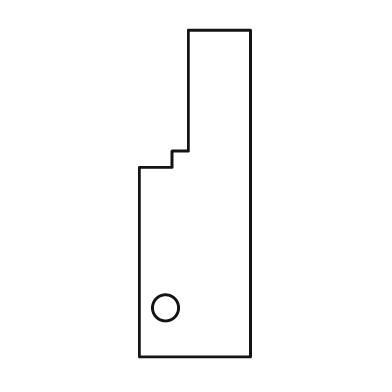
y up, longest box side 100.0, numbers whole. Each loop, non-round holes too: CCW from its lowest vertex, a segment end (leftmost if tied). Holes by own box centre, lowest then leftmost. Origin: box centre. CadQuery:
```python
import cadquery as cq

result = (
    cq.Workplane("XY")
    .moveTo(-17.0, -50.0)
    .lineTo(17.0, -50.0)
    .lineTo(17.0, 50.0)
    .lineTo(-2.0, 50.0)
    .lineTo(-2.0, 13.0)
    .lineTo(-7.0, 13.0)
    .lineTo(-7.0, 8.0)
    .lineTo(-17.0, 8.0)
    .close()
    .moveTo(-9.0, -35.0)
    .circle(4.0)
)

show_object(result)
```